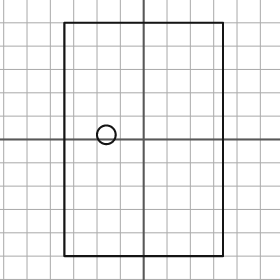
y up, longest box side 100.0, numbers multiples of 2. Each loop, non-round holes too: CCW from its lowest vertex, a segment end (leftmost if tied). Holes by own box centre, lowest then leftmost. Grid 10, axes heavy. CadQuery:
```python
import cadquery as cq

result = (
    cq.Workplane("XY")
    .moveTo(-34.0, -50.0)
    .lineTo(34.0, -50.0)
    .lineTo(34.0, 50.0)
    .lineTo(-34.0, 50.0)
    .close()
    .moveTo(-16.0, 2.0)
    .circle(4.0)
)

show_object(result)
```